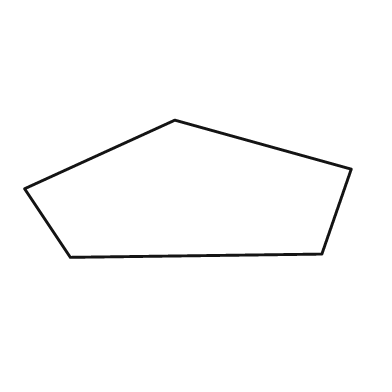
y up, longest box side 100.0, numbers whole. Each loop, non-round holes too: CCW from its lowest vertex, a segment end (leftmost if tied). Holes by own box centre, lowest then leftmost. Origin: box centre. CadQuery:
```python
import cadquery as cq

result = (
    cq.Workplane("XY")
    .moveTo(-36.0, -21.0)
    .lineTo(41.0, -20.0)
    .lineTo(50.0, 6.0)
    .lineTo(-4.0, 21.0)
    .lineTo(-50.0, 0.0)
    .close()
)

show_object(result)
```